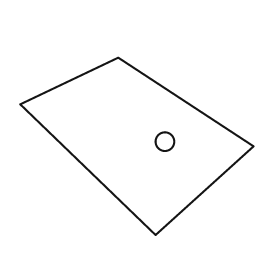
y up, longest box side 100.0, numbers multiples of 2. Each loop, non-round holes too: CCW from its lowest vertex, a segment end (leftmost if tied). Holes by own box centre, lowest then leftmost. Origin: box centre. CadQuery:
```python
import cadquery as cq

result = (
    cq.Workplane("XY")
    .moveTo(8.0, -38.0)
    .lineTo(50.0, 0.0)
    .lineTo(-8.0, 38.0)
    .lineTo(-50.0, 18.0)
    .close()
    .moveTo(12.0, 2.0)
    .circle(4.0)
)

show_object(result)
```